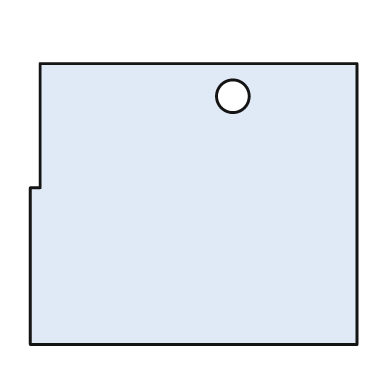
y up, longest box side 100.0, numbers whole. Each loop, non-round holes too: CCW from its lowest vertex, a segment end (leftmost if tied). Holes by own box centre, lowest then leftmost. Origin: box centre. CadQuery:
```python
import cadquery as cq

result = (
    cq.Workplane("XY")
    .moveTo(-50.0, -43.0)
    .lineTo(50.0, -43.0)
    .lineTo(50.0, 43.0)
    .lineTo(-47.0, 43.0)
    .lineTo(-47.0, 5.0)
    .lineTo(-50.0, 5.0)
    .close()
    .moveTo(12.0, 33.0)
    .circle(5.0)
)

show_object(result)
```